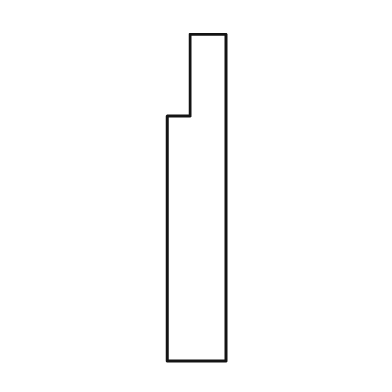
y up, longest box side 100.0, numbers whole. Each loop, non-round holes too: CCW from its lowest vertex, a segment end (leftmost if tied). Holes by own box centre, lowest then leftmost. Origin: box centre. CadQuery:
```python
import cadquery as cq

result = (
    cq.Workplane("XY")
    .moveTo(-9.0, -50.0)
    .lineTo(9.0, -50.0)
    .lineTo(9.0, 50.0)
    .lineTo(-2.0, 50.0)
    .lineTo(-2.0, 25.0)
    .lineTo(-9.0, 25.0)
    .close()
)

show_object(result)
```